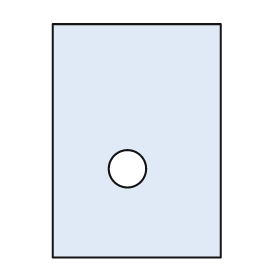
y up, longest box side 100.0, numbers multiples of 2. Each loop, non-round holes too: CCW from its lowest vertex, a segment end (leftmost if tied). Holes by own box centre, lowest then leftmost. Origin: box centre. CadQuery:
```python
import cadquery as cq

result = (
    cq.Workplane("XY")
    .moveTo(-36.0, -50.0)
    .lineTo(36.0, -50.0)
    .lineTo(36.0, 50.0)
    .lineTo(-36.0, 50.0)
    .close()
    .moveTo(-4.0, -12.0)
    .circle(8.0)
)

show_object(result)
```